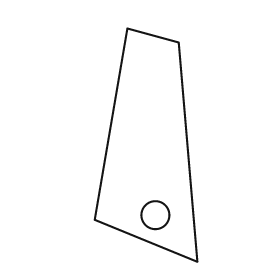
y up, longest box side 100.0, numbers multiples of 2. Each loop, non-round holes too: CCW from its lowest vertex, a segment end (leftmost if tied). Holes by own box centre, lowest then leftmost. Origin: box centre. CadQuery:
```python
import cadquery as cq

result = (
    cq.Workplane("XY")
    .moveTo(22.0, -50.0)
    .lineTo(14.0, 44.0)
    .lineTo(-8.0, 50.0)
    .lineTo(-22.0, -32.0)
    .close()
    .moveTo(4.0, -30.0)
    .circle(6.0)
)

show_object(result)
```